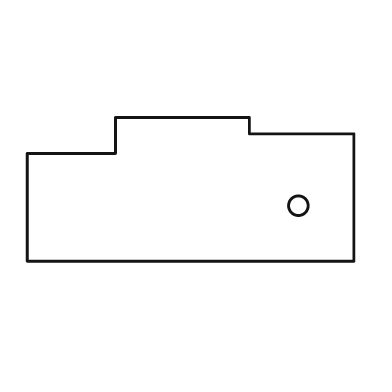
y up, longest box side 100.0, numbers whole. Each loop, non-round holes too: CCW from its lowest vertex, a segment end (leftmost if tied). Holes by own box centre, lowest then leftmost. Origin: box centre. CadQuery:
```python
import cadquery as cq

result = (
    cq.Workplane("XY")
    .moveTo(-50.0, -22.0)
    .lineTo(50.0, -22.0)
    .lineTo(50.0, 17.0)
    .lineTo(18.0, 17.0)
    .lineTo(18.0, 22.0)
    .lineTo(-23.0, 22.0)
    .lineTo(-23.0, 11.0)
    .lineTo(-50.0, 11.0)
    .close()
    .moveTo(33.0, -5.0)
    .circle(3.0)
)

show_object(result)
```